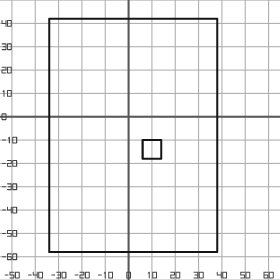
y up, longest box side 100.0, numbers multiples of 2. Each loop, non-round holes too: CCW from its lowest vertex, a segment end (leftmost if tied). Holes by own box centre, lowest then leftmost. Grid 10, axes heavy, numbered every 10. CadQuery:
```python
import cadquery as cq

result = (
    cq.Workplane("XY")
    .moveTo(-34.0, -58.0)
    .lineTo(38.0, -58.0)
    .lineTo(38.0, 42.0)
    .lineTo(-34.0, 42.0)
    .close()
    .moveTo(6.0, -18.0)
    .lineTo(14.0, -18.0)
    .lineTo(14.0, -10.0)
    .lineTo(6.0, -10.0)
    .close()
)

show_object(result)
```